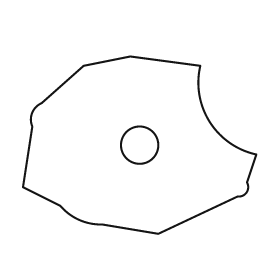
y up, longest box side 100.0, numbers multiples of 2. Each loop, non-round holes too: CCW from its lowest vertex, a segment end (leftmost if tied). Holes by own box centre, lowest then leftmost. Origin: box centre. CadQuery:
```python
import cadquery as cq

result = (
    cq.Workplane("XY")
    .moveTo(8.0, -38.0)
    .lineTo(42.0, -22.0)
    .threePointArc((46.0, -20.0), (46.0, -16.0))
    .lineTo(50.0, -4.0)
    .threePointArc((30.0, 10.0), (26.0, 34.0))
    .lineTo(-4.0, 38.0)
    .lineTo(-24.0, 34.0)
    .lineTo(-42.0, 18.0)
    .threePointArc((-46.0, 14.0), (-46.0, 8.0))
    .lineTo(-50.0, -18.0)
    .lineTo(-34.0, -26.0)
    .threePointArc((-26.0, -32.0), (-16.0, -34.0))
    .close()
    .moveTo(0.0, 0.0)
    .circle(8.0)
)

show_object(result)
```